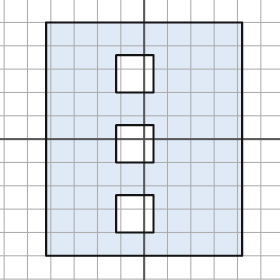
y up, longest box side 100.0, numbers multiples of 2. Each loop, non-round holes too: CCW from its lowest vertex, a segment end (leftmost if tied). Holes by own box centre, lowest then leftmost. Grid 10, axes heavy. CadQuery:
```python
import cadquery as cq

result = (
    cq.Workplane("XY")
    .moveTo(-42.0, -50.0)
    .lineTo(42.0, -50.0)
    .lineTo(42.0, 50.0)
    .lineTo(-42.0, 50.0)
    .close()
    .moveTo(-12.0, -40.0)
    .lineTo(4.0, -40.0)
    .lineTo(4.0, -24.0)
    .lineTo(-12.0, -24.0)
    .close()
    .moveTo(-12.0, -10.0)
    .lineTo(4.0, -10.0)
    .lineTo(4.0, 6.0)
    .lineTo(-12.0, 6.0)
    .close()
    .moveTo(-12.0, 20.0)
    .lineTo(4.0, 20.0)
    .lineTo(4.0, 36.0)
    .lineTo(-12.0, 36.0)
    .close()
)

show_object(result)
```